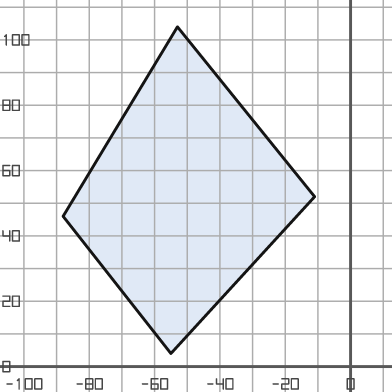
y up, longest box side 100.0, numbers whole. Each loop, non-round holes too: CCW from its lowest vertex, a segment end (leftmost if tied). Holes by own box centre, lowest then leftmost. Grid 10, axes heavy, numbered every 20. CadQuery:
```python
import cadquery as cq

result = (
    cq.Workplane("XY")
    .moveTo(-55.0, 4.0)
    .lineTo(-11.0, 52.0)
    .lineTo(-53.0, 104.0)
    .lineTo(-88.0, 46.0)
    .close()
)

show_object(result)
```